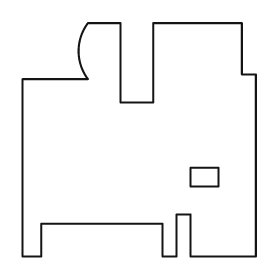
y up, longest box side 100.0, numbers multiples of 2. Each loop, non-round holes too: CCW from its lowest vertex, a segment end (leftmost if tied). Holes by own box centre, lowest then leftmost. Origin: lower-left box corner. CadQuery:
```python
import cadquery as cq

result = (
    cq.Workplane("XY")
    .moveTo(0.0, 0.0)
    .lineTo(8.0, 0.0)
    .lineTo(8.0, 14.0)
    .lineTo(60.0, 14.0)
    .lineTo(60.0, 0.0)
    .lineTo(66.0, 0.0)
    .lineTo(66.0, 18.0)
    .lineTo(72.0, 18.0)
    .lineTo(72.0, 0.0)
    .lineTo(100.0, 0.0)
    .lineTo(100.0, 78.0)
    .lineTo(94.0, 78.0)
    .lineTo(94.0, 100.0)
    .lineTo(56.0, 100.0)
    .lineTo(56.0, 66.0)
    .lineTo(42.0, 66.0)
    .lineTo(42.0, 100.0)
    .lineTo(28.0, 100.0)
    .threePointArc((24.0, 88.0), (28.0, 76.0))
    .lineTo(0.0, 76.0)
    .close()
    .moveTo(72.0, 30.0)
    .lineTo(84.0, 30.0)
    .lineTo(84.0, 38.0)
    .lineTo(72.0, 38.0)
    .close()
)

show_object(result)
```